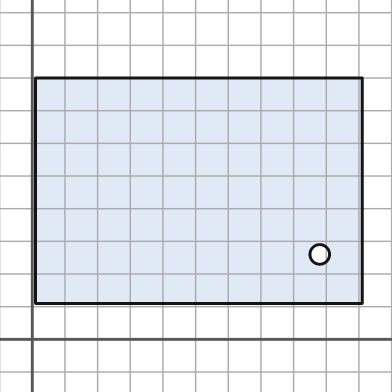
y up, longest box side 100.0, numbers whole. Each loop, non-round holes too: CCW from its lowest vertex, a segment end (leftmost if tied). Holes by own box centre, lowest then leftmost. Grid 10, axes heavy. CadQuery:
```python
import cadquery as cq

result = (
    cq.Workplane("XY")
    .moveTo(1.0, 11.0)
    .lineTo(101.0, 11.0)
    .lineTo(101.0, 80.0)
    .lineTo(1.0, 80.0)
    .close()
    .moveTo(88.0, 26.0)
    .circle(3.0)
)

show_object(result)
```